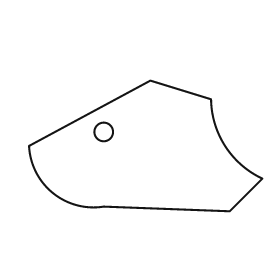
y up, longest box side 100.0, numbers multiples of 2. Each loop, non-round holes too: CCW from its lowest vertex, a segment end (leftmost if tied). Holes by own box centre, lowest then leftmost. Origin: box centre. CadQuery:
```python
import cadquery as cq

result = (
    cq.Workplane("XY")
    .moveTo(36.0, -28.0)
    .lineTo(50.0, -14.0)
    .threePointArc((34.0, 0.0), (28.0, 20.0))
    .lineTo(2.0, 28.0)
    .lineTo(-50.0, 0.0)
    .threePointArc((-40.0, -20.0), (-18.0, -26.0))
    .close()
    .moveTo(-18.0, 6.0)
    .circle(4.0)
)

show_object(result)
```